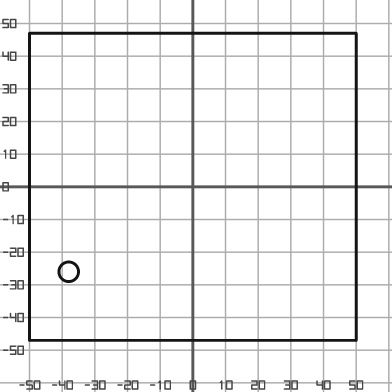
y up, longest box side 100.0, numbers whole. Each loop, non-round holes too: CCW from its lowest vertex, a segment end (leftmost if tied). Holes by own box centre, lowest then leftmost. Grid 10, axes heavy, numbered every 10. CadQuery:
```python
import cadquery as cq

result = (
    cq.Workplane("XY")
    .moveTo(-50.0, -47.0)
    .lineTo(50.0, -47.0)
    .lineTo(50.0, 47.0)
    .lineTo(-50.0, 47.0)
    .close()
    .moveTo(-38.0, -26.0)
    .circle(3.0)
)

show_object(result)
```